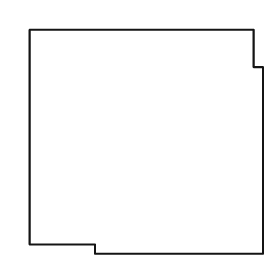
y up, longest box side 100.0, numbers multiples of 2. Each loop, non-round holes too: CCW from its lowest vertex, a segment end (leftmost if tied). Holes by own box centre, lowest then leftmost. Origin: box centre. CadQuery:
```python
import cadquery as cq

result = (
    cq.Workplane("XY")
    .moveTo(-22.0, -48.0)
    .lineTo(50.0, -48.0)
    .lineTo(50.0, 32.0)
    .lineTo(46.0, 32.0)
    .lineTo(46.0, 48.0)
    .lineTo(-50.0, 48.0)
    .lineTo(-50.0, -44.0)
    .lineTo(-22.0, -44.0)
    .close()
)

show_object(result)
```